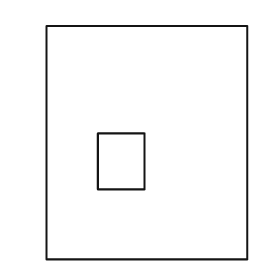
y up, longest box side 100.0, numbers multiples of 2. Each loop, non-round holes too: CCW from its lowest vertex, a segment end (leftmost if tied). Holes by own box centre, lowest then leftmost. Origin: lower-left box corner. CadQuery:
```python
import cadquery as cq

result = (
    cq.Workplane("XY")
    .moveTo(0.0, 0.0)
    .lineTo(86.0, 0.0)
    .lineTo(86.0, 100.0)
    .lineTo(0.0, 100.0)
    .close()
    .moveTo(22.0, 30.0)
    .lineTo(42.0, 30.0)
    .lineTo(42.0, 54.0)
    .lineTo(22.0, 54.0)
    .close()
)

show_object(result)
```